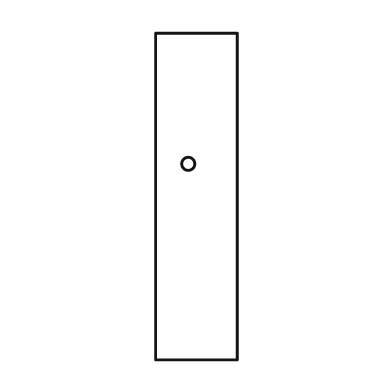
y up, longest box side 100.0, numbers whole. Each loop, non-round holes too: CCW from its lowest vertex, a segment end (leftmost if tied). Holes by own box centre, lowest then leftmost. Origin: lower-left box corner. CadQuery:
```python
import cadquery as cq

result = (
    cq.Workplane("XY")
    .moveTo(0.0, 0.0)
    .lineTo(25.0, 0.0)
    .lineTo(25.0, 100.0)
    .lineTo(0.0, 100.0)
    .close()
    .moveTo(10.0, 60.0)
    .circle(2.0)
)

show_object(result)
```